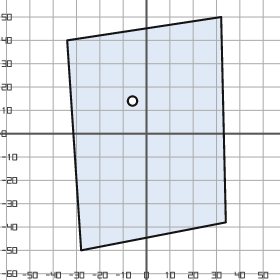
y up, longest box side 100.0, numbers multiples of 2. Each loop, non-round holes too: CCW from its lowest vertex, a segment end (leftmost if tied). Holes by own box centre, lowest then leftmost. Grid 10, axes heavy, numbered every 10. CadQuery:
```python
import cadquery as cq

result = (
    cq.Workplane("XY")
    .moveTo(-28.0, -50.0)
    .lineTo(34.0, -38.0)
    .lineTo(32.0, 50.0)
    .lineTo(-34.0, 40.0)
    .close()
    .moveTo(-6.0, 14.0)
    .circle(2.0)
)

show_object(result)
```